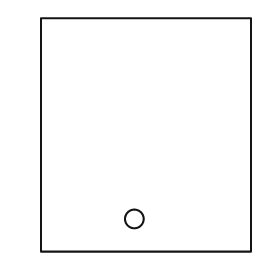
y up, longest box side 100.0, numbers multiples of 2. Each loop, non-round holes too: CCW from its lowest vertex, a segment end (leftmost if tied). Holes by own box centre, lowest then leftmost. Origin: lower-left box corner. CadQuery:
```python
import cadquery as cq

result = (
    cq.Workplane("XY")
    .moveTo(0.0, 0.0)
    .lineTo(90.0, 0.0)
    .lineTo(90.0, 100.0)
    .lineTo(0.0, 100.0)
    .close()
    .moveTo(40.0, 14.0)
    .circle(4.0)
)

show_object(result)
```